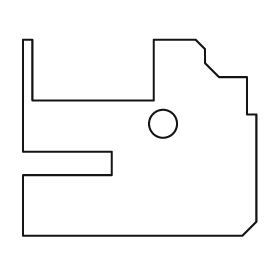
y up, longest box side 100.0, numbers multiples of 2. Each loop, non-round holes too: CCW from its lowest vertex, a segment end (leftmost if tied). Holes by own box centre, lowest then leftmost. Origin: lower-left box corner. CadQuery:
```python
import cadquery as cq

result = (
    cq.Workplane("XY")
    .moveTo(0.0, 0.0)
    .lineTo(94.0, 0.0)
    .lineTo(100.0, 6.0)
    .lineTo(100.0, 52.0)
    .lineTo(96.0, 52.0)
    .lineTo(96.0, 68.0)
    .lineTo(84.0, 68.0)
    .lineTo(78.0, 74.0)
    .lineTo(78.0, 80.0)
    .lineTo(74.0, 84.0)
    .lineTo(56.0, 84.0)
    .lineTo(56.0, 58.0)
    .lineTo(4.0, 58.0)
    .lineTo(4.0, 84.0)
    .lineTo(0.0, 84.0)
    .lineTo(0.0, 36.0)
    .lineTo(38.0, 36.0)
    .lineTo(38.0, 26.0)
    .lineTo(0.0, 26.0)
    .close()
    .moveTo(60.0, 48.0)
    .circle(6.0)
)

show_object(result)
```